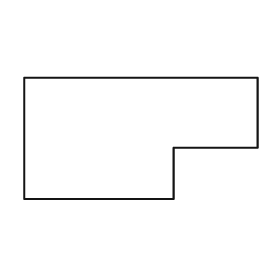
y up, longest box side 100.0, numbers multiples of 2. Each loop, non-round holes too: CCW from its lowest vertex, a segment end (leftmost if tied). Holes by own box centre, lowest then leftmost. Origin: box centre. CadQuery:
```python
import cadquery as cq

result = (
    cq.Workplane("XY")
    .moveTo(-50.0, -26.0)
    .lineTo(14.0, -26.0)
    .lineTo(14.0, -4.0)
    .lineTo(50.0, -4.0)
    .lineTo(50.0, 26.0)
    .lineTo(-50.0, 26.0)
    .close()
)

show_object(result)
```